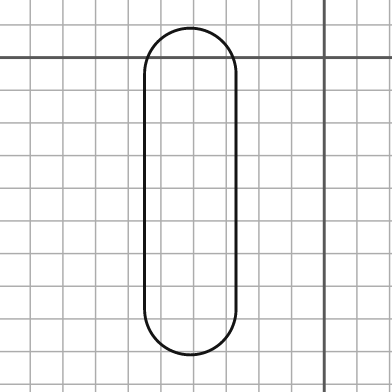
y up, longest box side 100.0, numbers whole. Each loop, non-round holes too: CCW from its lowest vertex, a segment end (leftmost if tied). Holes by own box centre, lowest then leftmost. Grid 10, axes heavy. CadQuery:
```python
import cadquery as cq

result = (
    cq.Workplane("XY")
    .moveTo(-55.0, -77.0)
    .threePointArc((-41.0, -91.0), (-27.0, -77.0))
    .lineTo(-27.0, -5.0)
    .threePointArc((-41.0, 9.0), (-55.0, -5.0))
    .close()
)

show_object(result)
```